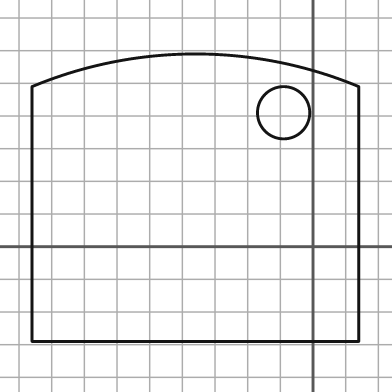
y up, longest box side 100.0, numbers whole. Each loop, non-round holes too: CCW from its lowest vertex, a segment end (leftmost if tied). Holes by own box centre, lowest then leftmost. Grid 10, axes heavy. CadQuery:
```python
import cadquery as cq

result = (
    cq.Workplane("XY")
    .moveTo(-86.0, -29.0)
    .lineTo(14.0, -29.0)
    .lineTo(14.0, 49.0)
    .threePointArc((-36.0, 59.0), (-86.0, 49.0))
    .close()
    .moveTo(-9.0, 41.0)
    .circle(8.0)
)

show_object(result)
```